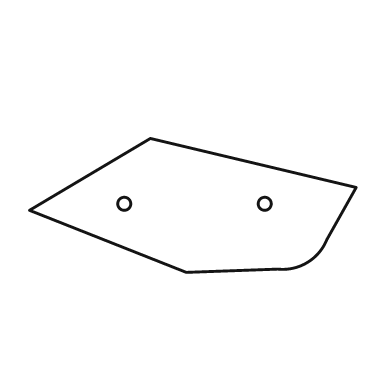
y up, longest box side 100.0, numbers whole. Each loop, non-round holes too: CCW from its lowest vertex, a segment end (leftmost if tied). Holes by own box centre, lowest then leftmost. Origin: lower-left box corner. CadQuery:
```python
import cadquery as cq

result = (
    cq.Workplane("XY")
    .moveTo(48.0, 0.0)
    .lineTo(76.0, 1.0)
    .threePointArc((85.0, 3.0), (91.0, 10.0))
    .lineTo(100.0, 26.0)
    .lineTo(37.0, 41.0)
    .lineTo(0.0, 19.0)
    .close()
    .moveTo(29.0, 21.0)
    .circle(2.0)
    .moveTo(72.0, 21.0)
    .circle(2.0)
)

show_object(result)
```